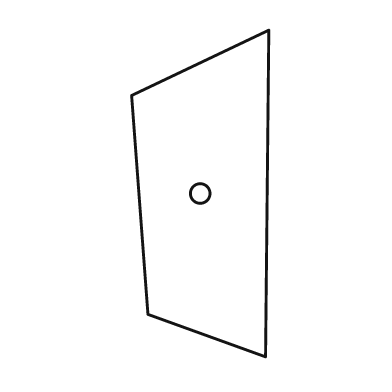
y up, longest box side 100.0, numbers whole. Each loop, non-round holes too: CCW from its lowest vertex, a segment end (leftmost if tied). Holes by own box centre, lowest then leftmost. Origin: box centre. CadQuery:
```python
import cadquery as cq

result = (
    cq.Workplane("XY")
    .moveTo(20.0, -50.0)
    .lineTo(21.0, 50.0)
    .lineTo(-21.0, 30.0)
    .lineTo(-16.0, -37.0)
    .close()
    .moveTo(0.0, 0.0)
    .circle(3.0)
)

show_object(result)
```